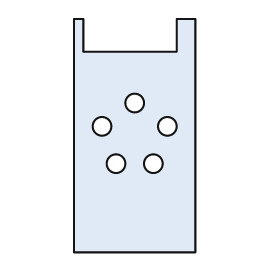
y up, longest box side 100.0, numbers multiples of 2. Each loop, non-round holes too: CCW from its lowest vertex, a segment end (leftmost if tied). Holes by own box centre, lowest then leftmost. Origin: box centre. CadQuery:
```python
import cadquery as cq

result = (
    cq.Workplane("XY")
    .moveTo(-26.0, -50.0)
    .lineTo(26.0, -50.0)
    .lineTo(26.0, 50.0)
    .lineTo(18.0, 50.0)
    .lineTo(18.0, 36.0)
    .lineTo(-22.0, 36.0)
    .lineTo(-22.0, 50.0)
    .lineTo(-26.0, 50.0)
    .close()
    .moveTo(-8.0, -12.0)
    .circle(4.0)
    .moveTo(8.0, -12.0)
    .circle(4.0)
    .moveTo(-14.0, 4.0)
    .circle(4.0)
    .moveTo(14.0, 4.0)
    .circle(4.0)
    .moveTo(0.0, 14.0)
    .circle(4.0)
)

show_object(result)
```